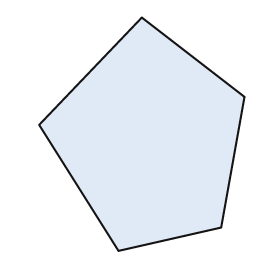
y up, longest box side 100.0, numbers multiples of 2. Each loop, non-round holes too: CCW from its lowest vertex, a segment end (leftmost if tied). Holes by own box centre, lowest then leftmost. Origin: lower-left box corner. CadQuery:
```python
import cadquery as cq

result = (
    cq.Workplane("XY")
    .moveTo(34.0, 0.0)
    .lineTo(78.0, 10.0)
    .lineTo(88.0, 66.0)
    .lineTo(44.0, 100.0)
    .lineTo(0.0, 54.0)
    .close()
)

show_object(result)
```